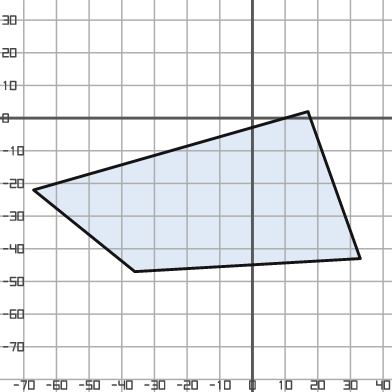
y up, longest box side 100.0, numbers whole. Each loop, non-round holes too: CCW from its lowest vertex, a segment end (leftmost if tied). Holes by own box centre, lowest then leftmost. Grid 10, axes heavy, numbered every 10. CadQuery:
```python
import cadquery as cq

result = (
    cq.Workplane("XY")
    .moveTo(-36.0, -47.0)
    .lineTo(33.0, -43.0)
    .lineTo(17.0, 2.0)
    .lineTo(-67.0, -22.0)
    .close()
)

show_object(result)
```